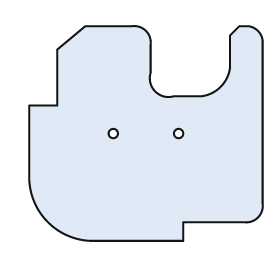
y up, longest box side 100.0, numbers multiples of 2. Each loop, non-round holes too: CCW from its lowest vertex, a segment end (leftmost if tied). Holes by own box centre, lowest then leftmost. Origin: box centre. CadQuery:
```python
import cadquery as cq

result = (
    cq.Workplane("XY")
    .moveTo(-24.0, -46.0)
    .lineTo(16.0, -46.0)
    .lineTo(16.0, -38.0)
    .lineTo(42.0, -38.0)
    .threePointArc((48.0, -36.0), (50.0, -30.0))
    .lineTo(50.0, 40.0)
    .threePointArc((48.0, 44.0), (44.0, 46.0))
    .lineTo(40.0, 46.0)
    .lineTo(36.0, 42.0)
    .lineTo(36.0, 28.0)
    .threePointArc((32.0, 20.0), (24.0, 16.0))
    .lineTo(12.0, 16.0)
    .threePointArc((4.0, 18.0), (2.0, 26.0))
    .lineTo(2.0, 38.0)
    .threePointArc((0.0, 44.0), (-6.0, 46.0))
    .lineTo(-26.0, 46.0)
    .lineTo(-38.0, 36.0)
    .lineTo(-38.0, 12.0)
    .lineTo(-50.0, 12.0)
    .lineTo(-50.0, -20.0)
    .threePointArc((-42.0, -38.0), (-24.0, -46.0))
    .close()
    .moveTo(-14.0, 0.0)
    .circle(2.0)
    .moveTo(14.0, 0.0)
    .circle(2.0)
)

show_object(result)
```